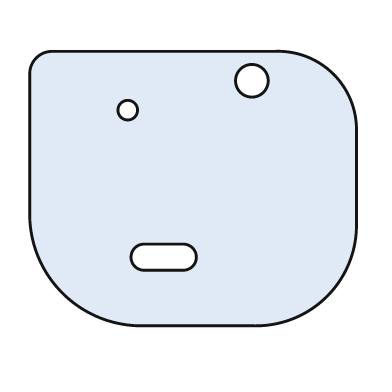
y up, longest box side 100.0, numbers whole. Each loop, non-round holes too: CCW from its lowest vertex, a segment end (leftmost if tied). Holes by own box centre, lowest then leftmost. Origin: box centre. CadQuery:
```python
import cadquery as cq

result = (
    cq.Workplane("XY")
    .moveTo(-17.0, -42.0)
    .lineTo(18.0, -42.0)
    .threePointArc((41.0, -33.0), (50.0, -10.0))
    .lineTo(50.0, 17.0)
    .threePointArc((43.0, 35.0), (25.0, 42.0))
    .lineTo(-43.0, 42.0)
    .threePointArc((-48.0, 40.0), (-50.0, 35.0))
    .lineTo(-50.0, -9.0)
    .threePointArc((-40.0, -32.0), (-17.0, -42.0))
    .close()
    .moveTo(-15.0, -25.0)
    .lineTo(-3.0, -25.0)
    .threePointArc((1.0, -21.0), (-3.0, -17.0))
    .lineTo(-15.0, -17.0)
    .threePointArc((-19.0, -21.0), (-15.0, -25.0))
    .close()
    .moveTo(-20.0, 24.0)
    .circle(3.0)
    .moveTo(18.0, 33.0)
    .circle(5.0)
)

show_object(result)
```